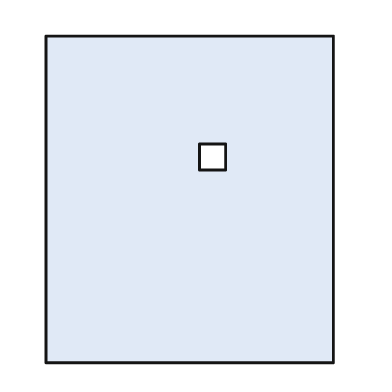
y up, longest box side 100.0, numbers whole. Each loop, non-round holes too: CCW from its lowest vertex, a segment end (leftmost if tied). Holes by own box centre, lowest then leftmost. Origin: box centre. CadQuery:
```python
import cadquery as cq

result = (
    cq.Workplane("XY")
    .moveTo(-44.0, -50.0)
    .lineTo(44.0, -50.0)
    .lineTo(44.0, 50.0)
    .lineTo(-44.0, 50.0)
    .close()
    .moveTo(3.0, 9.0)
    .lineTo(11.0, 9.0)
    .lineTo(11.0, 17.0)
    .lineTo(3.0, 17.0)
    .close()
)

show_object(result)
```